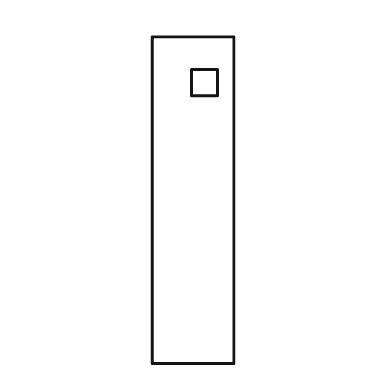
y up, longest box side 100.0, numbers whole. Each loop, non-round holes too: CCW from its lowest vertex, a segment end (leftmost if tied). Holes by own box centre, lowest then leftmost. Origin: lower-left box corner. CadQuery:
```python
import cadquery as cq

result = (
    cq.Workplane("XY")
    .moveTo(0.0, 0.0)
    .lineTo(25.0, 0.0)
    .lineTo(25.0, 100.0)
    .lineTo(0.0, 100.0)
    .close()
    .moveTo(12.0, 82.0)
    .lineTo(20.0, 82.0)
    .lineTo(20.0, 90.0)
    .lineTo(12.0, 90.0)
    .close()
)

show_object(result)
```